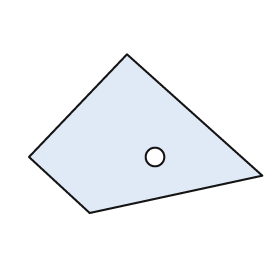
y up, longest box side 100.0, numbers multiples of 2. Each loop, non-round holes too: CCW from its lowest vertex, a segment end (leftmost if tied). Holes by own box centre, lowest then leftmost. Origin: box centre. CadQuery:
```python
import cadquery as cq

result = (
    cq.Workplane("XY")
    .moveTo(-24.0, -34.0)
    .lineTo(50.0, -18.0)
    .lineTo(-8.0, 34.0)
    .lineTo(-50.0, -10.0)
    .close()
    .moveTo(4.0, -10.0)
    .circle(4.0)
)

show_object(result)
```